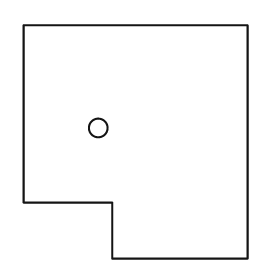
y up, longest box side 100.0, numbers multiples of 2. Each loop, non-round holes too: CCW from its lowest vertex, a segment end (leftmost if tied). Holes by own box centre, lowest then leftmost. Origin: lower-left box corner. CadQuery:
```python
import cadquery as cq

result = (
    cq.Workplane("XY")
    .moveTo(38.0, 0.0)
    .lineTo(96.0, 0.0)
    .lineTo(96.0, 100.0)
    .lineTo(0.0, 100.0)
    .lineTo(0.0, 24.0)
    .lineTo(38.0, 24.0)
    .close()
    .moveTo(32.0, 56.0)
    .circle(4.0)
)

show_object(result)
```